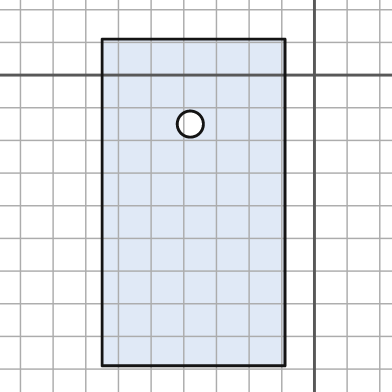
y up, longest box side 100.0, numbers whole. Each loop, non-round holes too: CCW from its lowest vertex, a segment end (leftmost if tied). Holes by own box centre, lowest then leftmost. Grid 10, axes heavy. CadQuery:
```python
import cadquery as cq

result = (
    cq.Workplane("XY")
    .moveTo(-65.0, -89.0)
    .lineTo(-9.0, -89.0)
    .lineTo(-9.0, 11.0)
    .lineTo(-65.0, 11.0)
    .close()
    .moveTo(-38.0, -15.0)
    .circle(4.0)
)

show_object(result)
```